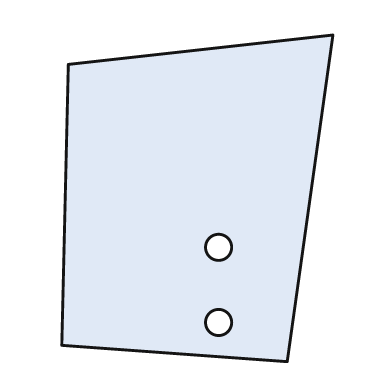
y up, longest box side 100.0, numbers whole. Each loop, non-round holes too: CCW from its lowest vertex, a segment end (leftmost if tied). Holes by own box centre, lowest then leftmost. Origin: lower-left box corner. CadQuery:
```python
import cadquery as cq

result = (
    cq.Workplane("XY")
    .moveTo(69.0, 0.0)
    .lineTo(83.0, 100.0)
    .lineTo(2.0, 91.0)
    .lineTo(0.0, 5.0)
    .close()
    .moveTo(48.0, 12.0)
    .circle(4.0)
    .moveTo(48.0, 35.0)
    .circle(4.0)
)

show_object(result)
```